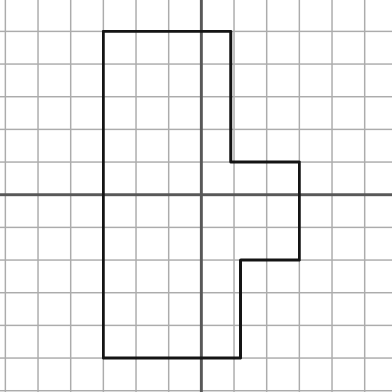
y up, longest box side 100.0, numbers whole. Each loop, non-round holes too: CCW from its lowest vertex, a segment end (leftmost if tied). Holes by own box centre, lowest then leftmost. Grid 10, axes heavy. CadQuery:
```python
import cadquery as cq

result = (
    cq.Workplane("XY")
    .moveTo(-30.0, -50.0)
    .lineTo(12.0, -50.0)
    .lineTo(12.0, -20.0)
    .lineTo(30.0, -20.0)
    .lineTo(30.0, 10.0)
    .lineTo(9.0, 10.0)
    .lineTo(9.0, 50.0)
    .lineTo(-30.0, 50.0)
    .close()
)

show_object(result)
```